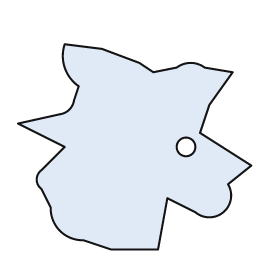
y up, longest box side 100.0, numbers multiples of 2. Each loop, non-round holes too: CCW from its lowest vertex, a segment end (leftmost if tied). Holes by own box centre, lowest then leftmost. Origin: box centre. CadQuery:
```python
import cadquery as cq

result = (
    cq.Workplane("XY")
    .moveTo(-10.0, -44.0)
    .lineTo(10.0, -44.0)
    .lineTo(14.0, -22.0)
    .lineTo(26.0, -28.0)
    .threePointArc((38.0, -28.0), (40.0, -16.0))
    .lineTo(50.0, -8.0)
    .lineTo(28.0, 6.0)
    .lineTo(32.0, 18.0)
    .lineTo(42.0, 32.0)
    .lineTo(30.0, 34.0)
    .threePointArc((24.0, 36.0), (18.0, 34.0))
    .lineTo(8.0, 32.0)
    .lineTo(2.0, 36.0)
    .lineTo(-14.0, 42.0)
    .lineTo(-30.0, 44.0)
    .threePointArc((-30.0, 34.0), (-24.0, 26.0))
    .lineTo(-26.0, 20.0)
    .threePointArc((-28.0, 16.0), (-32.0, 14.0))
    .lineTo(-50.0, 10.0)
    .lineTo(-30.0, 0.0)
    .lineTo(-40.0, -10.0)
    .threePointArc((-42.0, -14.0), (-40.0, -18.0))
    .lineTo(-36.0, -26.0)
    .threePointArc((-32.0, -36.0), (-22.0, -40.0))
    .close()
    .moveTo(22.0, 0.0)
    .circle(4.0)
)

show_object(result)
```